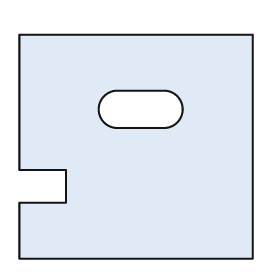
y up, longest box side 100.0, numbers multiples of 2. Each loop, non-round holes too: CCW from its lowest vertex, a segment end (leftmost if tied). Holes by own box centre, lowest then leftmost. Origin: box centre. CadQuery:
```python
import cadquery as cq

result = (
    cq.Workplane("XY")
    .moveTo(-50.0, -48.0)
    .lineTo(50.0, -48.0)
    .lineTo(50.0, 48.0)
    .lineTo(-50.0, 48.0)
    .lineTo(-50.0, -10.0)
    .lineTo(-30.0, -10.0)
    .lineTo(-30.0, -24.0)
    .lineTo(-50.0, -24.0)
    .close()
    .moveTo(-8.0, 8.0)
    .lineTo(12.0, 8.0)
    .threePointArc((20.0, 16.0), (12.0, 24.0))
    .lineTo(-8.0, 24.0)
    .threePointArc((-16.0, 16.0), (-8.0, 8.0))
    .close()
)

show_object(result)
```